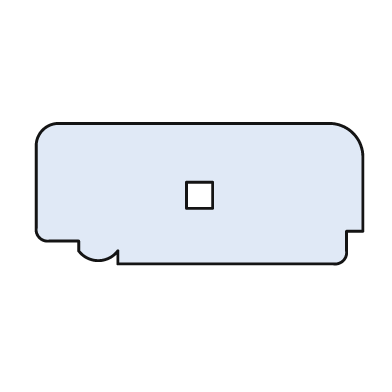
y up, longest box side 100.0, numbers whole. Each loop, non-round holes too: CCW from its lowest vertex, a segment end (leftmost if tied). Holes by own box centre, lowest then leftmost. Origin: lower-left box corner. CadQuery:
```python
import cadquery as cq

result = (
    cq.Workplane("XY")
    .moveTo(25.0, 0.0)
    .lineTo(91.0, 0.0)
    .threePointArc((94.0, 1.0), (95.0, 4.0))
    .lineTo(95.0, 10.0)
    .lineTo(100.0, 10.0)
    .lineTo(100.0, 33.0)
    .threePointArc((97.0, 40.0), (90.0, 43.0))
    .lineTo(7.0, 43.0)
    .threePointArc((2.0, 41.0), (0.0, 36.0))
    .lineTo(0.0, 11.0)
    .threePointArc((1.0, 8.0), (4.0, 7.0))
    .lineTo(13.0, 7.0)
    .lineTo(13.0, 4.0)
    .threePointArc((19.0, 1.0), (25.0, 4.0))
    .close()
    .moveTo(46.0, 17.0)
    .lineTo(54.0, 17.0)
    .lineTo(54.0, 25.0)
    .lineTo(46.0, 25.0)
    .close()
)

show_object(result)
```